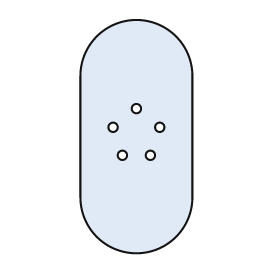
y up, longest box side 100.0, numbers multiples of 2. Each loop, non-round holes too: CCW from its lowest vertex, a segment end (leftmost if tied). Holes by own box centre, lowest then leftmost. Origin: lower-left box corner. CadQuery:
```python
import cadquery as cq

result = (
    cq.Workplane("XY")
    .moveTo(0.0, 24.0)
    .threePointArc((24.0, 0.0), (48.0, 24.0))
    .lineTo(48.0, 76.0)
    .threePointArc((24.0, 100.0), (0.0, 76.0))
    .close()
    .moveTo(18.0, 42.0)
    .circle(2.0)
    .moveTo(30.0, 42.0)
    .circle(2.0)
    .moveTo(14.0, 54.0)
    .circle(2.0)
    .moveTo(34.0, 54.0)
    .circle(2.0)
    .moveTo(24.0, 62.0)
    .circle(2.0)
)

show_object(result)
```